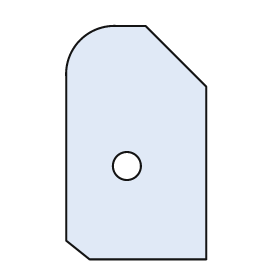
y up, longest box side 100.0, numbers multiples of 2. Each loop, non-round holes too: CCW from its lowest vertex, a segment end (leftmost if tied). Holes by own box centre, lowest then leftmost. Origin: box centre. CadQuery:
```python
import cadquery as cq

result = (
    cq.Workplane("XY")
    .moveTo(-20.0, -50.0)
    .lineTo(30.0, -50.0)
    .lineTo(30.0, 24.0)
    .lineTo(4.0, 50.0)
    .lineTo(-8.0, 50.0)
    .threePointArc((-24.0, 44.0), (-30.0, 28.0))
    .lineTo(-30.0, -42.0)
    .close()
    .moveTo(-4.0, -10.0)
    .circle(6.0)
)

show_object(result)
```